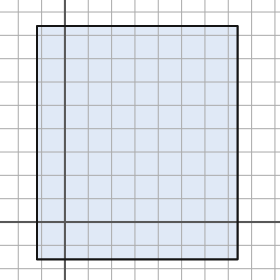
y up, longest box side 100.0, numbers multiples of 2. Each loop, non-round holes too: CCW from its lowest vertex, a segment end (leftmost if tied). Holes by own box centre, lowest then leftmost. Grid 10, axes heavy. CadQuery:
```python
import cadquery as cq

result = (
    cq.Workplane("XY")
    .moveTo(-12.0, -16.0)
    .lineTo(74.0, -16.0)
    .lineTo(74.0, 84.0)
    .lineTo(-12.0, 84.0)
    .close()
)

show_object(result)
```